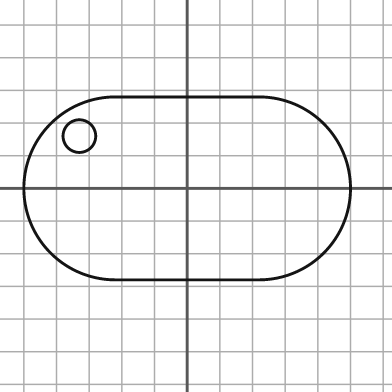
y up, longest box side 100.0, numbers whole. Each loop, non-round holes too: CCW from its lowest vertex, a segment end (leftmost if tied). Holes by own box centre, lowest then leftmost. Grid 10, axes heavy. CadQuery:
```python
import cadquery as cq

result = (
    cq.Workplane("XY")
    .moveTo(-22.0, -28.0)
    .lineTo(22.0, -28.0)
    .threePointArc((50.0, 0.0), (22.0, 28.0))
    .lineTo(-22.0, 28.0)
    .threePointArc((-50.0, 0.0), (-22.0, -28.0))
    .close()
    .moveTo(-33.0, 16.0)
    .circle(5.0)
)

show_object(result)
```